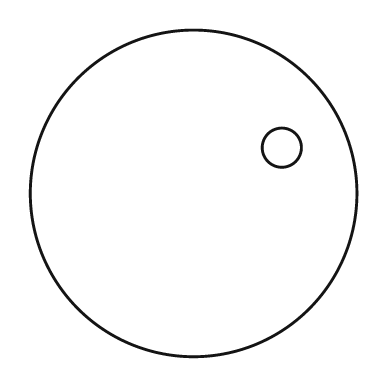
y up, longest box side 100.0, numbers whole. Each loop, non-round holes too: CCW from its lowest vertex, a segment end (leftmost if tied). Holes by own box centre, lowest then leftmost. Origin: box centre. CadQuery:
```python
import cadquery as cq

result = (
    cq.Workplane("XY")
    .moveTo(0.0, 0.0)
    .circle(50.0)
    .moveTo(27.0, 14.0)
    .circle(6.0)
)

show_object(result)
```